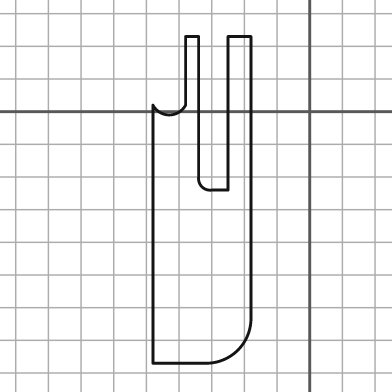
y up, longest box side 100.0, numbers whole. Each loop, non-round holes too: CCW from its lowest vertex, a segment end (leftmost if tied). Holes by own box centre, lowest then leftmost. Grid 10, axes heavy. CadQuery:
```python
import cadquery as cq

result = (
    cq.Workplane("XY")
    .moveTo(-48.0, -77.0)
    .lineTo(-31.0, -77.0)
    .threePointArc((-22.0, -73.0), (-18.0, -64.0))
    .lineTo(-18.0, 23.0)
    .lineTo(-25.0, 23.0)
    .lineTo(-25.0, -24.0)
    .lineTo(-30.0, -24.0)
    .threePointArc((-33.0, -23.0), (-34.0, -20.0))
    .lineTo(-34.0, 23.0)
    .lineTo(-38.0, 23.0)
    .lineTo(-38.0, 2.0)
    .threePointArc((-43.0, -1.0), (-48.0, 2.0))
    .close()
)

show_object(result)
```